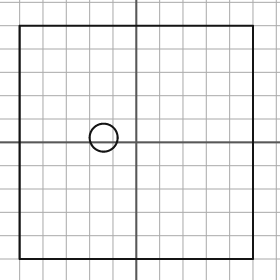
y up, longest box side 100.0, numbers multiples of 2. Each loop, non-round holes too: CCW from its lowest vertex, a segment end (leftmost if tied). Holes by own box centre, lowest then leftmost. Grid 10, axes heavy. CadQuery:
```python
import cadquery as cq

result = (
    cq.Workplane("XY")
    .moveTo(-50.0, -50.0)
    .lineTo(50.0, -50.0)
    .lineTo(50.0, 50.0)
    .lineTo(-50.0, 50.0)
    .close()
    .moveTo(-14.0, 2.0)
    .circle(6.0)
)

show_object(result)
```